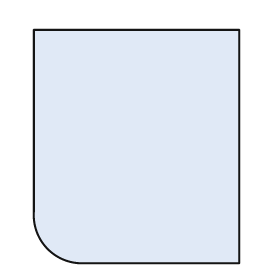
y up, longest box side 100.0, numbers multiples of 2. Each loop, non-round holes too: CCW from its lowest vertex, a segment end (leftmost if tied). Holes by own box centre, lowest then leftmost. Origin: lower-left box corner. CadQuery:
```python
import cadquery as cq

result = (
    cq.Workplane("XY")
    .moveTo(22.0, 0.0)
    .lineTo(88.0, 0.0)
    .lineTo(88.0, 100.0)
    .lineTo(0.0, 100.0)
    .lineTo(0.0, 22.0)
    .threePointArc((6.0, 6.0), (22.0, 0.0))
    .close()
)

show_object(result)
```